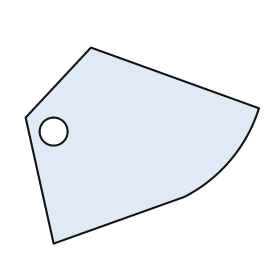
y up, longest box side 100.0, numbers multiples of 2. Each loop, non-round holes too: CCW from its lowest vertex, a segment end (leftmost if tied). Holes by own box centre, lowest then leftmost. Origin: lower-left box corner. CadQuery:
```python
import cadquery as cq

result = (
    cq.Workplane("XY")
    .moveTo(12.0, 0.0)
    .lineTo(68.0, 20.0)
    .threePointArc((88.0, 36.0), (100.0, 58.0))
    .lineTo(28.0, 84.0)
    .lineTo(0.0, 54.0)
    .close()
    .moveTo(12.0, 48.0)
    .circle(6.0)
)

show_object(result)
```